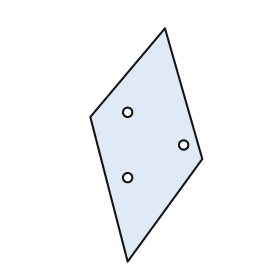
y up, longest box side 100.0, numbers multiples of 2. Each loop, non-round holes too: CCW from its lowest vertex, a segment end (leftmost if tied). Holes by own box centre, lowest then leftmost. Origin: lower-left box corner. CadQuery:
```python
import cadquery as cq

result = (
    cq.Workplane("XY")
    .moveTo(16.0, 0.0)
    .lineTo(48.0, 44.0)
    .lineTo(32.0, 100.0)
    .lineTo(0.0, 62.0)
    .close()
    .moveTo(16.0, 36.0)
    .circle(2.0)
    .moveTo(40.0, 50.0)
    .circle(2.0)
    .moveTo(16.0, 64.0)
    .circle(2.0)
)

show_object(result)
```